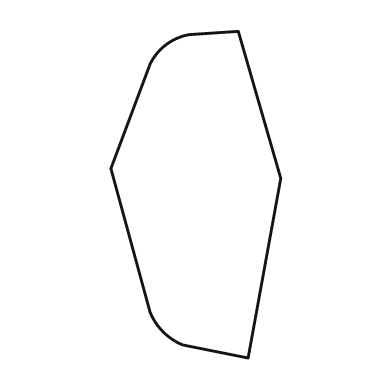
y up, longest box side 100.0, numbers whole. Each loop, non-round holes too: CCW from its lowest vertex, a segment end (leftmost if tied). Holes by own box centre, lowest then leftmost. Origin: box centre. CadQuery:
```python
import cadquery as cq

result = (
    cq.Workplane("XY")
    .moveTo(16.0, -50.0)
    .lineTo(26.0, 5.0)
    .lineTo(13.0, 50.0)
    .lineTo(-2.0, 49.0)
    .threePointArc((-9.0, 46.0), (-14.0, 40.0))
    .lineTo(-26.0, 8.0)
    .lineTo(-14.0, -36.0)
    .threePointArc((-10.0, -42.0), (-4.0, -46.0))
    .close()
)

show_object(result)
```